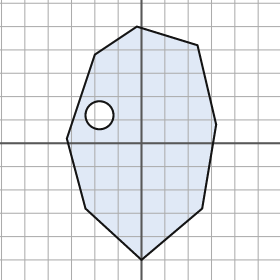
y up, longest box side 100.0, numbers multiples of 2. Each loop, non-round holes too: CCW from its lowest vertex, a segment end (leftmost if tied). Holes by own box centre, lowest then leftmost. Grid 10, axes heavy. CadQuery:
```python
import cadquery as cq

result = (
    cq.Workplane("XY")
    .moveTo(0.0, -50.0)
    .lineTo(26.0, -28.0)
    .lineTo(32.0, 8.0)
    .lineTo(24.0, 42.0)
    .lineTo(-2.0, 50.0)
    .lineTo(-20.0, 38.0)
    .lineTo(-32.0, 2.0)
    .lineTo(-24.0, -28.0)
    .close()
    .moveTo(-18.0, 12.0)
    .circle(6.0)
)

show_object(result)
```